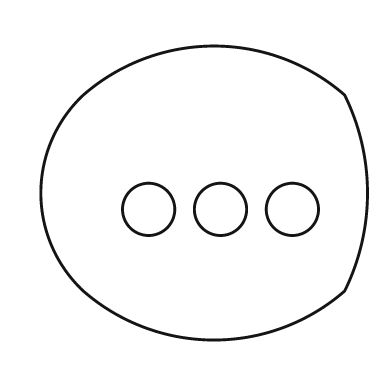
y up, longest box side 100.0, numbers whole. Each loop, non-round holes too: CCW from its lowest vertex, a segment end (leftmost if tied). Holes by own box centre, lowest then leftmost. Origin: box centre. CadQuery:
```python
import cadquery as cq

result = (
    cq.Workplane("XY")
    .moveTo(-37.0, -30.0)
    .threePointArc((3.0, -45.0), (43.0, -30.0))
    .threePointArc((50.0, 0.0), (43.0, 30.0))
    .threePointArc((3.0, 45.0), (-37.0, 30.0))
    .threePointArc((-50.0, 0.0), (-37.0, -30.0))
    .close()
    .moveTo(-17.0, -5.0)
    .circle(8.0)
    .moveTo(5.0, -5.0)
    .circle(8.0)
    .moveTo(27.0, -5.0)
    .circle(8.0)
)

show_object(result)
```